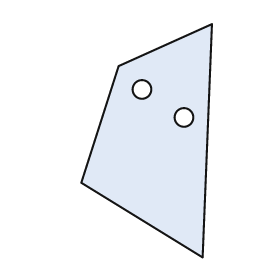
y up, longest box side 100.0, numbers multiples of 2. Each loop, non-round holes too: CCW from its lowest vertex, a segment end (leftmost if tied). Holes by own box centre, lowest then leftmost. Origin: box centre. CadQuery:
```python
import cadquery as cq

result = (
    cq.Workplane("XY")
    .moveTo(24.0, -50.0)
    .lineTo(28.0, 50.0)
    .lineTo(-12.0, 32.0)
    .lineTo(-28.0, -18.0)
    .close()
    .moveTo(16.0, 10.0)
    .circle(4.0)
    .moveTo(-2.0, 22.0)
    .circle(4.0)
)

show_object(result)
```